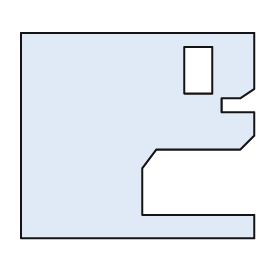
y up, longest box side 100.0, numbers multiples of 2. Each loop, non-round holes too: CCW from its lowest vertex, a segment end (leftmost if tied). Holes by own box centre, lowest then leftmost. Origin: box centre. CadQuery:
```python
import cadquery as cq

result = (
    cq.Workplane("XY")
    .moveTo(-50.0, -44.0)
    .lineTo(50.0, -44.0)
    .lineTo(50.0, -34.0)
    .lineTo(2.0, -34.0)
    .lineTo(2.0, -14.0)
    .lineTo(8.0, -6.0)
    .lineTo(44.0, -6.0)
    .lineTo(50.0, 0.0)
    .lineTo(50.0, 10.0)
    .lineTo(36.0, 10.0)
    .lineTo(36.0, 16.0)
    .lineTo(44.0, 16.0)
    .lineTo(50.0, 20.0)
    .lineTo(50.0, 44.0)
    .lineTo(-50.0, 44.0)
    .close()
    .moveTo(20.0, 18.0)
    .lineTo(32.0, 18.0)
    .lineTo(32.0, 38.0)
    .lineTo(20.0, 38.0)
    .close()
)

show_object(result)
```